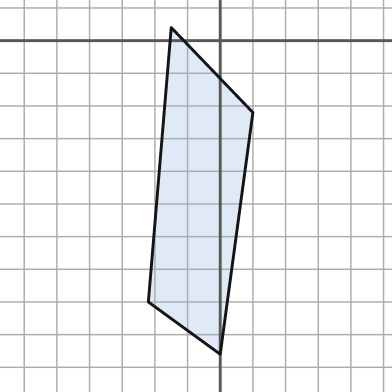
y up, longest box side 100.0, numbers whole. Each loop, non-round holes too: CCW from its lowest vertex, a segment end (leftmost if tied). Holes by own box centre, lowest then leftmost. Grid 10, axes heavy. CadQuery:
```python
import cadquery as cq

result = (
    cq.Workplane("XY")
    .moveTo(0.0, -96.0)
    .lineTo(10.0, -22.0)
    .lineTo(-15.0, 4.0)
    .lineTo(-22.0, -80.0)
    .close()
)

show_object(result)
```